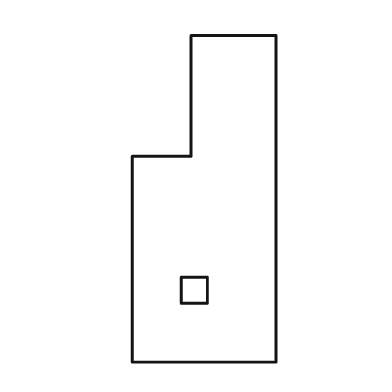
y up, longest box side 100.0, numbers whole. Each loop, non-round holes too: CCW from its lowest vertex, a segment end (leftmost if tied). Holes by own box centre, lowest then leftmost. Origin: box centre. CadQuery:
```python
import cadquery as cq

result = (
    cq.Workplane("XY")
    .moveTo(-22.0, -50.0)
    .lineTo(22.0, -50.0)
    .lineTo(22.0, 50.0)
    .lineTo(-4.0, 50.0)
    .lineTo(-4.0, 13.0)
    .lineTo(-22.0, 13.0)
    .close()
    .moveTo(-7.0, -32.0)
    .lineTo(1.0, -32.0)
    .lineTo(1.0, -24.0)
    .lineTo(-7.0, -24.0)
    .close()
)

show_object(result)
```